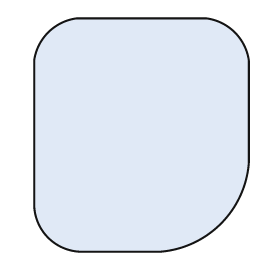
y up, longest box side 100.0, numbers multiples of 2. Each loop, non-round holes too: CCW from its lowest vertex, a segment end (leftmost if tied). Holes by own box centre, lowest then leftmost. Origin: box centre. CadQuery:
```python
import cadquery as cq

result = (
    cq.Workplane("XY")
    .moveTo(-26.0, -50.0)
    .lineTo(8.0, -50.0)
    .threePointArc((34.0, -38.0), (46.0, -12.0))
    .lineTo(46.0, 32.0)
    .threePointArc((40.0, 44.0), (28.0, 50.0))
    .lineTo(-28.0, 50.0)
    .threePointArc((-40.0, 44.0), (-46.0, 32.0))
    .lineTo(-46.0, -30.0)
    .threePointArc((-40.0, -44.0), (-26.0, -50.0))
    .close()
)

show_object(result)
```